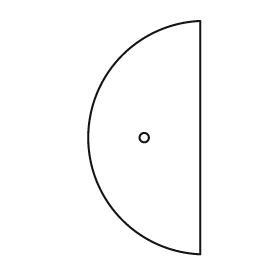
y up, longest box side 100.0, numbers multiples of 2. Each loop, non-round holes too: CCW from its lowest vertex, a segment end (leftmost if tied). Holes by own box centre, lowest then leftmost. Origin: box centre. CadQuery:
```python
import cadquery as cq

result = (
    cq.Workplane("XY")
    .moveTo(24.0, -50.0)
    .lineTo(24.0, 50.0)
    .threePointArc((-24.0, 0.0), (24.0, -50.0))
    .close()
    .moveTo(0.0, 0.0)
    .circle(2.0)
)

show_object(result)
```